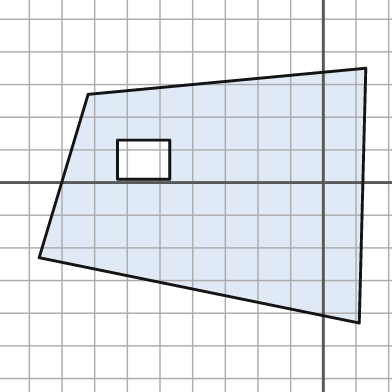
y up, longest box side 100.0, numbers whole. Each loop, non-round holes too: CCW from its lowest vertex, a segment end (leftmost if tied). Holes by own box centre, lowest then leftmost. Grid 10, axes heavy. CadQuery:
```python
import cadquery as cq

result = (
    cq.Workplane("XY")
    .moveTo(11.0, -43.0)
    .lineTo(13.0, 35.0)
    .lineTo(-72.0, 27.0)
    .lineTo(-87.0, -23.0)
    .close()
    .moveTo(-63.0, 1.0)
    .lineTo(-47.0, 1.0)
    .lineTo(-47.0, 13.0)
    .lineTo(-63.0, 13.0)
    .close()
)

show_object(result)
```